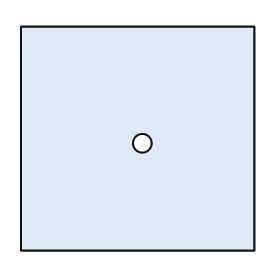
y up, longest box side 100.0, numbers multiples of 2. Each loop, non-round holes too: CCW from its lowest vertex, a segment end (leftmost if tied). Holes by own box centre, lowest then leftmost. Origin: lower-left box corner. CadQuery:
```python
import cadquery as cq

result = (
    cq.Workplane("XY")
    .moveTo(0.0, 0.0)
    .lineTo(100.0, 0.0)
    .lineTo(100.0, 96.0)
    .lineTo(0.0, 96.0)
    .close()
    .moveTo(52.0, 46.0)
    .circle(4.0)
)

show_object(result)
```